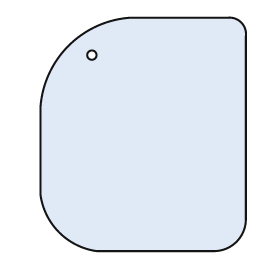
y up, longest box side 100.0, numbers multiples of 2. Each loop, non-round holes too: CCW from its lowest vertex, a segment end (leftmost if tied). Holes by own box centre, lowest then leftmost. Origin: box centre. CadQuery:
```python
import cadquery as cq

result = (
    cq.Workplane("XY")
    .moveTo(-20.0, -50.0)
    .lineTo(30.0, -50.0)
    .threePointArc((40.0, -46.0), (44.0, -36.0))
    .lineTo(44.0, 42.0)
    .threePointArc((42.0, 48.0), (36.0, 50.0))
    .lineTo(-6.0, 50.0)
    .threePointArc((-32.0, 38.0), (-44.0, 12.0))
    .lineTo(-44.0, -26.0)
    .threePointArc((-36.0, -42.0), (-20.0, -50.0))
    .close()
    .moveTo(-22.0, 34.0)
    .circle(2.0)
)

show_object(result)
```